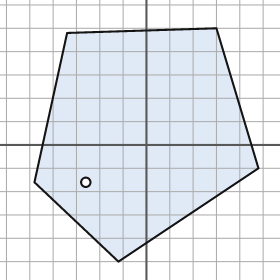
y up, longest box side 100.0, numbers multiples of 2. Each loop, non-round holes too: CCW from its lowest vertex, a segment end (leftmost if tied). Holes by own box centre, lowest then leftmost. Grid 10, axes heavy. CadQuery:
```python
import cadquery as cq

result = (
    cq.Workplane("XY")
    .moveTo(-12.0, -50.0)
    .lineTo(48.0, -10.0)
    .lineTo(30.0, 50.0)
    .lineTo(-34.0, 48.0)
    .lineTo(-48.0, -16.0)
    .close()
    .moveTo(-26.0, -16.0)
    .circle(2.0)
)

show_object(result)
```